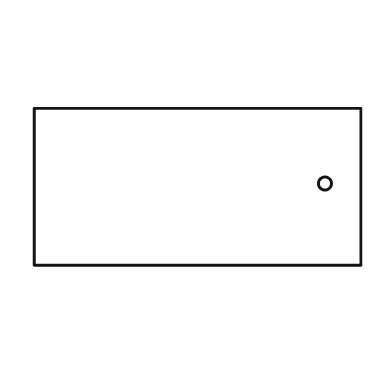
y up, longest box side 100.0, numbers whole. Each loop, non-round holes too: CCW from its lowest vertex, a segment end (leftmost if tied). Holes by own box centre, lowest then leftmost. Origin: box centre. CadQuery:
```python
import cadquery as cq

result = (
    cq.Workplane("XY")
    .moveTo(-50.0, -24.0)
    .lineTo(50.0, -24.0)
    .lineTo(50.0, 24.0)
    .lineTo(-50.0, 24.0)
    .close()
    .moveTo(39.0, 1.0)
    .circle(2.0)
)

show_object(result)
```